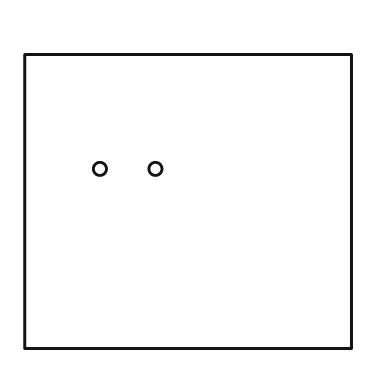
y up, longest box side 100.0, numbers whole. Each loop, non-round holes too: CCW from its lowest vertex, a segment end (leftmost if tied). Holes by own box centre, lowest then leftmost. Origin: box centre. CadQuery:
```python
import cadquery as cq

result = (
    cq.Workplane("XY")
    .moveTo(-50.0, -45.0)
    .lineTo(50.0, -45.0)
    .lineTo(50.0, 45.0)
    .lineTo(-50.0, 45.0)
    .close()
    .moveTo(-27.0, 10.0)
    .circle(2.0)
    .moveTo(-10.0, 10.0)
    .circle(2.0)
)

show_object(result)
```